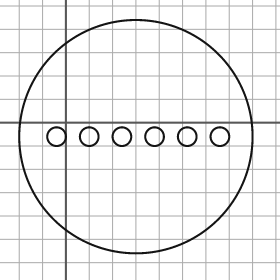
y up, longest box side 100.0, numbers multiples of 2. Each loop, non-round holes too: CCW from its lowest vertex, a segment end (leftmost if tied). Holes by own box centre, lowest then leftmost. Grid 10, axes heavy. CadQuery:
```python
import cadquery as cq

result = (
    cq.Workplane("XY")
    .moveTo(30.0, -6.0)
    .circle(50.0)
    .moveTo(-4.0, -6.0)
    .circle(4.0)
    .moveTo(10.0, -6.0)
    .circle(4.0)
    .moveTo(24.0, -6.0)
    .circle(4.0)
    .moveTo(38.0, -6.0)
    .circle(4.0)
    .moveTo(52.0, -6.0)
    .circle(4.0)
    .moveTo(66.0, -6.0)
    .circle(4.0)
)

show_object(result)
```